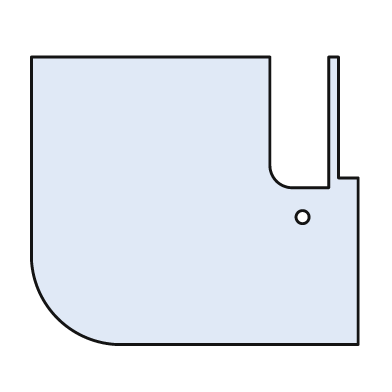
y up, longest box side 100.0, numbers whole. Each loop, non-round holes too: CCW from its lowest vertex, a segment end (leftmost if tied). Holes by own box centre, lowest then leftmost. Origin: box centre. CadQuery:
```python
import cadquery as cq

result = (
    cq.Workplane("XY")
    .moveTo(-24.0, -44.0)
    .lineTo(50.0, -44.0)
    .lineTo(50.0, 7.0)
    .lineTo(44.0, 7.0)
    .lineTo(44.0, 44.0)
    .lineTo(41.0, 44.0)
    .lineTo(41.0, 4.0)
    .lineTo(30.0, 4.0)
    .threePointArc((25.0, 6.0), (23.0, 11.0))
    .lineTo(23.0, 44.0)
    .lineTo(-50.0, 44.0)
    .lineTo(-50.0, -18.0)
    .threePointArc((-42.0, -36.0), (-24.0, -44.0))
    .close()
    .moveTo(33.0, -5.0)
    .circle(2.0)
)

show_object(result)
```